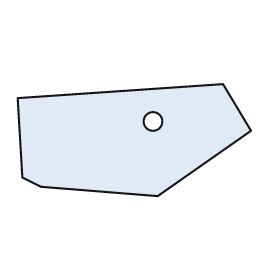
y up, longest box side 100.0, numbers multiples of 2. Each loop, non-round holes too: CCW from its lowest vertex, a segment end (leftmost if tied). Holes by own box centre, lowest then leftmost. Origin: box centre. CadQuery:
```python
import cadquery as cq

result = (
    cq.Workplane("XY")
    .moveTo(10.0, -24.0)
    .lineTo(50.0, 4.0)
    .lineTo(38.0, 24.0)
    .lineTo(-50.0, 18.0)
    .lineTo(-48.0, -16.0)
    .lineTo(-40.0, -20.0)
    .close()
    .moveTo(8.0, 8.0)
    .circle(4.0)
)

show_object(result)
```